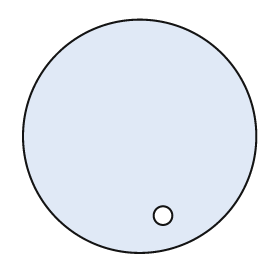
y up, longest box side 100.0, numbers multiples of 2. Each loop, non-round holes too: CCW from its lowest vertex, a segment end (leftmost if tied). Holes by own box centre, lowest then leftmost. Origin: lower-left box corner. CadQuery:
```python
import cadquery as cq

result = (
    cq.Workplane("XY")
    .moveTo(50.0, 50.0)
    .circle(50.0)
    .moveTo(60.0, 16.0)
    .circle(4.0)
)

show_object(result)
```